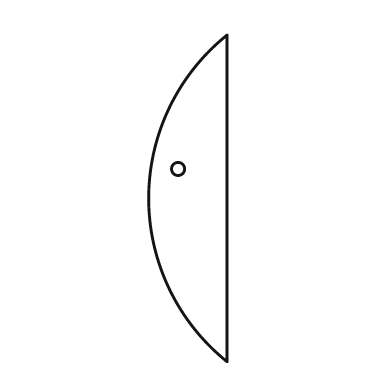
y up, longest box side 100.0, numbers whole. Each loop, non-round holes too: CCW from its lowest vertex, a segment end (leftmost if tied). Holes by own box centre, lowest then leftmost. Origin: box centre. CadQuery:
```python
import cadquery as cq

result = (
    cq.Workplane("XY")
    .moveTo(12.0, -50.0)
    .lineTo(12.0, 50.0)
    .threePointArc((-12.0, 0.0), (12.0, -50.0))
    .close()
    .moveTo(-3.0, 9.0)
    .circle(2.0)
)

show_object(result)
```